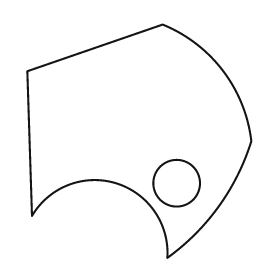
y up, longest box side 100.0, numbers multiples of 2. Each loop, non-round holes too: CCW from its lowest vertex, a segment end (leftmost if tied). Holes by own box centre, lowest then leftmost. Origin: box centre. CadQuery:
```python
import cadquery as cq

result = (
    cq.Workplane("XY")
    .moveTo(12.0, -50.0)
    .threePointArc((34.0, -28.0), (48.0, 0.0))
    .threePointArc((36.0, 30.0), (10.0, 50.0))
    .lineTo(-48.0, 30.0)
    .lineTo(-46.0, -32.0)
    .threePointArc((-10.0, -18.0), (12.0, -50.0))
    .close()
    .moveTo(16.0, -18.0)
    .circle(10.0)
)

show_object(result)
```